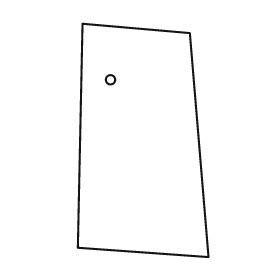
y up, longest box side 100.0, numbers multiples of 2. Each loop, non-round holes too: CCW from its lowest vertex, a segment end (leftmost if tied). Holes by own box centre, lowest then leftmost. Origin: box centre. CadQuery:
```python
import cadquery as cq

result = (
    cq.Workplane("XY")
    .moveTo(28.0, -50.0)
    .lineTo(20.0, 46.0)
    .lineTo(-26.0, 50.0)
    .lineTo(-28.0, -46.0)
    .close()
    .moveTo(-14.0, 26.0)
    .circle(2.0)
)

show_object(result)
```